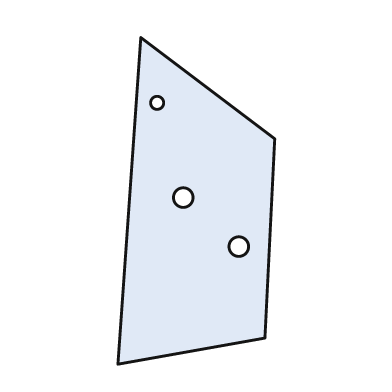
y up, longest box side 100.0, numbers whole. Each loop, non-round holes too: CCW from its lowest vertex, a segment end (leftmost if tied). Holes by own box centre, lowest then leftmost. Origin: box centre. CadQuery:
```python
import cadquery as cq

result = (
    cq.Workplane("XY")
    .moveTo(-24.0, -50.0)
    .lineTo(21.0, -42.0)
    .lineTo(24.0, 19.0)
    .lineTo(-17.0, 50.0)
    .close()
    .moveTo(13.0, -14.0)
    .circle(3.0)
    .moveTo(-4.0, 1.0)
    .circle(3.0)
    .moveTo(-12.0, 30.0)
    .circle(2.0)
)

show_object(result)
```